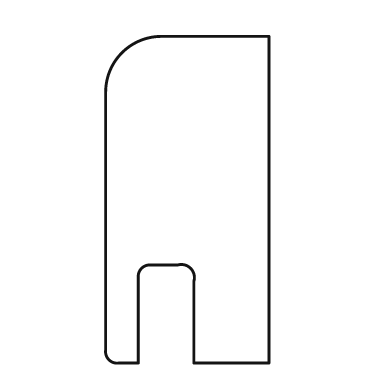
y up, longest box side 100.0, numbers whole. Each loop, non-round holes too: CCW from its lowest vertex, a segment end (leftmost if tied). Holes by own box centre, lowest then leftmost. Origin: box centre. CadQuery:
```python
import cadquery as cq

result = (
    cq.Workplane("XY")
    .moveTo(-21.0, -50.0)
    .lineTo(-15.0, -50.0)
    .lineTo(-15.0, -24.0)
    .threePointArc((-14.0, -21.0), (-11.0, -20.0))
    .lineTo(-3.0, -20.0)
    .threePointArc((1.0, -21.0), (2.0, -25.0))
    .lineTo(2.0, -50.0)
    .lineTo(25.0, -50.0)
    .lineTo(25.0, 50.0)
    .lineTo(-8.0, 50.0)
    .threePointArc((-20.0, 45.0), (-25.0, 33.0))
    .lineTo(-25.0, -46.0)
    .threePointArc((-24.0, -49.0), (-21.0, -50.0))
    .close()
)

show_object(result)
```